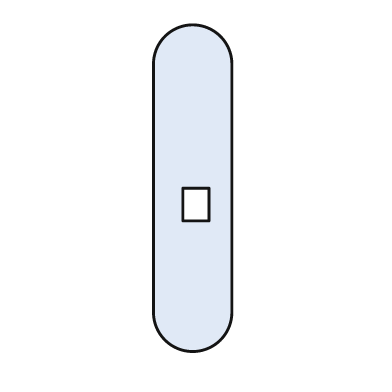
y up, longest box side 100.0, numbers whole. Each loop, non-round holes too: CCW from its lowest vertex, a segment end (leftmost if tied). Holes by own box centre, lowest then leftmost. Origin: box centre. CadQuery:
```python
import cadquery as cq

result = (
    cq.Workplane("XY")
    .moveTo(-12.0, -38.0)
    .threePointArc((0.0, -50.0), (12.0, -38.0))
    .lineTo(12.0, 38.0)
    .threePointArc((0.0, 50.0), (-12.0, 38.0))
    .close()
    .moveTo(-3.0, -10.0)
    .lineTo(5.0, -10.0)
    .lineTo(5.0, 0.0)
    .lineTo(-3.0, 0.0)
    .close()
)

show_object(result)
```